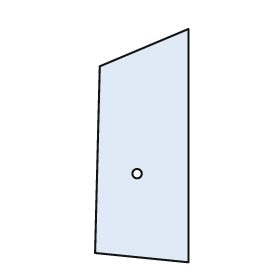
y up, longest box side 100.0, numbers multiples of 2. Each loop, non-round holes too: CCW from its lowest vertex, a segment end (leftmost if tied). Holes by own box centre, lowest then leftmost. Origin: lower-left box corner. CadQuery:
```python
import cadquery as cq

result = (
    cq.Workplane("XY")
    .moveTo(40.0, 0.0)
    .lineTo(40.0, 100.0)
    .lineTo(2.0, 84.0)
    .lineTo(0.0, 4.0)
    .close()
    .moveTo(18.0, 38.0)
    .circle(2.0)
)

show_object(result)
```